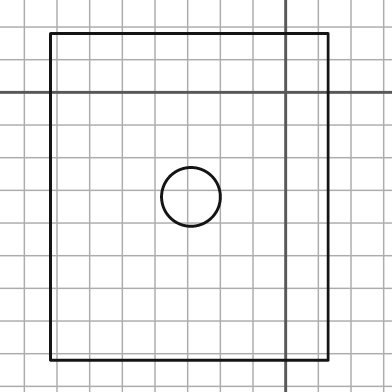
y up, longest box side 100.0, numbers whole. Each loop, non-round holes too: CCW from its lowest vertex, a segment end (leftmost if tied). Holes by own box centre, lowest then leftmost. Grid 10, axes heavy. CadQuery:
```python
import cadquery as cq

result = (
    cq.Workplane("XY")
    .moveTo(-72.0, -82.0)
    .lineTo(13.0, -82.0)
    .lineTo(13.0, 18.0)
    .lineTo(-72.0, 18.0)
    .close()
    .moveTo(-29.0, -32.0)
    .circle(9.0)
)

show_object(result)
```